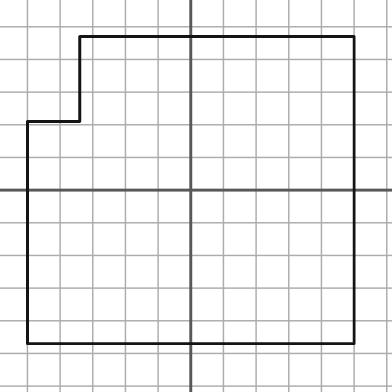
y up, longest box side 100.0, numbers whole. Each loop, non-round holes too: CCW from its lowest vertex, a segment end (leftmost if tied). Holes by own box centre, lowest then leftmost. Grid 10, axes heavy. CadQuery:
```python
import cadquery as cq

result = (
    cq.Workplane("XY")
    .moveTo(-50.0, -47.0)
    .lineTo(50.0, -47.0)
    .lineTo(50.0, 47.0)
    .lineTo(-34.0, 47.0)
    .lineTo(-34.0, 21.0)
    .lineTo(-50.0, 21.0)
    .close()
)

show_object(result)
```